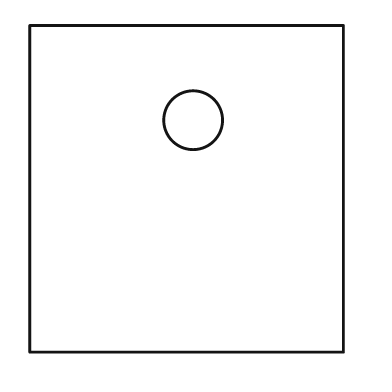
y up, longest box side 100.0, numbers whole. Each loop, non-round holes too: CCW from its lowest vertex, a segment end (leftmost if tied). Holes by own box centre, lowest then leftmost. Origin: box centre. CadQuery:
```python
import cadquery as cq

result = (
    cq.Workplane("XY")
    .moveTo(-48.0, -50.0)
    .lineTo(48.0, -50.0)
    .lineTo(48.0, 50.0)
    .lineTo(-48.0, 50.0)
    .close()
    .moveTo(2.0, 21.0)
    .circle(9.0)
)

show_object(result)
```